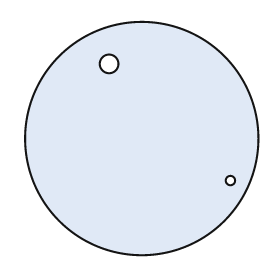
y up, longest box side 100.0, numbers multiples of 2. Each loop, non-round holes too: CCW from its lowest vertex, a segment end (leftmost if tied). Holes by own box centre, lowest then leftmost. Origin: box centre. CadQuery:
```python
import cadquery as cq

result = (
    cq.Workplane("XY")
    .moveTo(0.0, 0.0)
    .circle(50.0)
    .moveTo(38.0, -18.0)
    .circle(2.0)
    .moveTo(-14.0, 32.0)
    .circle(4.0)
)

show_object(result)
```